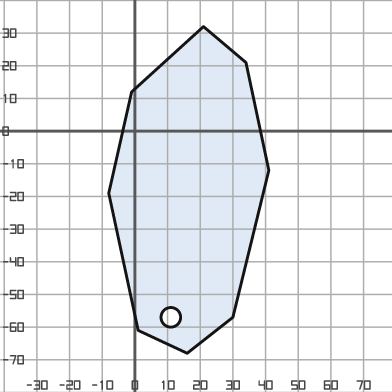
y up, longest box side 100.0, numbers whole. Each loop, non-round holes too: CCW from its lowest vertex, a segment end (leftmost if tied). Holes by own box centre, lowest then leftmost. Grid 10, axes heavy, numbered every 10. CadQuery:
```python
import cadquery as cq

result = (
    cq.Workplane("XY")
    .moveTo(16.0, -68.0)
    .lineTo(30.0, -57.0)
    .lineTo(41.0, -12.0)
    .lineTo(34.0, 21.0)
    .lineTo(21.0, 32.0)
    .lineTo(-1.0, 12.0)
    .lineTo(-8.0, -19.0)
    .lineTo(1.0, -61.0)
    .close()
    .moveTo(11.0, -57.0)
    .circle(3.0)
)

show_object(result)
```